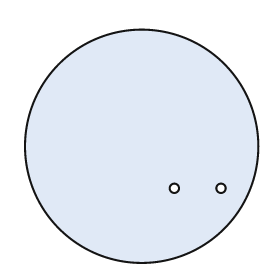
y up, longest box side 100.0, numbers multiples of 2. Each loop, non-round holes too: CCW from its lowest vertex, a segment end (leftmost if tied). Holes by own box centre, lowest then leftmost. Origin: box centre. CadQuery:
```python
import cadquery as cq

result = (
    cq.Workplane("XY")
    .moveTo(0.0, 0.0)
    .circle(50.0)
    .moveTo(14.0, -18.0)
    .circle(2.0)
    .moveTo(34.0, -18.0)
    .circle(2.0)
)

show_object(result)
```